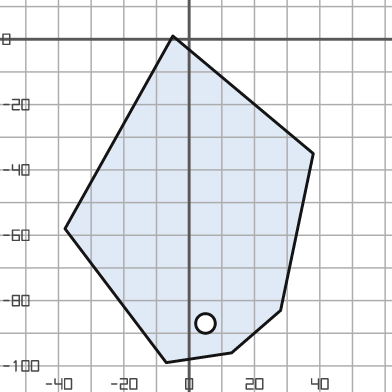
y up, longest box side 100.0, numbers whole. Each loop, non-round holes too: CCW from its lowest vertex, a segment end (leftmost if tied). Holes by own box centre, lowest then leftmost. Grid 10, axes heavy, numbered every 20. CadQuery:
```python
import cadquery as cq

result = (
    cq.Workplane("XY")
    .moveTo(-7.0, -99.0)
    .lineTo(13.0, -96.0)
    .lineTo(28.0, -83.0)
    .lineTo(38.0, -35.0)
    .lineTo(-5.0, 1.0)
    .lineTo(-38.0, -58.0)
    .close()
    .moveTo(5.0, -87.0)
    .circle(3.0)
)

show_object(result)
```